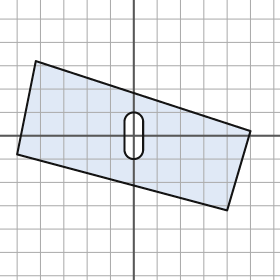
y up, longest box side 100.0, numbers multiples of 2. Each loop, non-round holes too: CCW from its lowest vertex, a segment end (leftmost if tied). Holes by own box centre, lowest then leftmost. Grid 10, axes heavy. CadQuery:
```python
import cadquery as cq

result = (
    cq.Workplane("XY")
    .moveTo(40.0, -32.0)
    .lineTo(50.0, 2.0)
    .lineTo(-42.0, 32.0)
    .lineTo(-50.0, -8.0)
    .close()
    .moveTo(-4.0, -6.0)
    .threePointArc((0.0, -10.0), (4.0, -6.0))
    .lineTo(4.0, 6.0)
    .threePointArc((0.0, 10.0), (-4.0, 6.0))
    .close()
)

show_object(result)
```